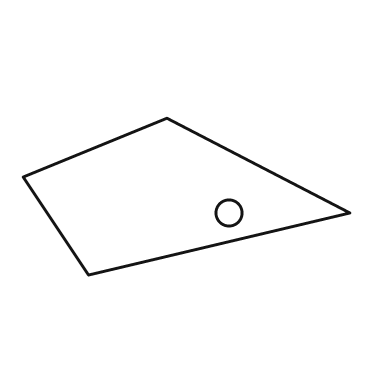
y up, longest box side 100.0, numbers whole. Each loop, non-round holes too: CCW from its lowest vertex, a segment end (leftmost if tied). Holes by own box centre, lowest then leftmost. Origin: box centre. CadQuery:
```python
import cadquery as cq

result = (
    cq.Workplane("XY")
    .moveTo(-30.0, -24.0)
    .lineTo(50.0, -5.0)
    .lineTo(-6.0, 24.0)
    .lineTo(-50.0, 6.0)
    .close()
    .moveTo(13.0, -5.0)
    .circle(4.0)
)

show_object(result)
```